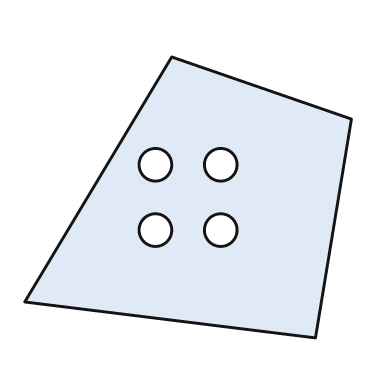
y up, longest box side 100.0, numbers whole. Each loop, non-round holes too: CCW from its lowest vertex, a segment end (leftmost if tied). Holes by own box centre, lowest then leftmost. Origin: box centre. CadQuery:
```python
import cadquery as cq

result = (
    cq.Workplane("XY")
    .moveTo(39.0, -43.0)
    .lineTo(50.0, 24.0)
    .lineTo(-5.0, 43.0)
    .lineTo(-50.0, -32.0)
    .close()
    .moveTo(-10.0, -10.0)
    .circle(5.0)
    .moveTo(10.0, -10.0)
    .circle(5.0)
    .moveTo(-10.0, 10.0)
    .circle(5.0)
    .moveTo(10.0, 10.0)
    .circle(5.0)
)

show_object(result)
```